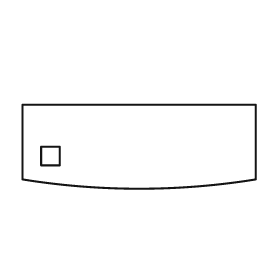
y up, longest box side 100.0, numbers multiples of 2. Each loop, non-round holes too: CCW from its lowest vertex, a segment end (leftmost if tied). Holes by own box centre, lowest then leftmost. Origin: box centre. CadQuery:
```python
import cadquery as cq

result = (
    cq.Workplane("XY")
    .moveTo(-50.0, -14.0)
    .threePointArc((0.0, -18.0), (50.0, -14.0))
    .lineTo(50.0, 18.0)
    .lineTo(-50.0, 18.0)
    .close()
    .moveTo(-42.0, -8.0)
    .lineTo(-34.0, -8.0)
    .lineTo(-34.0, 0.0)
    .lineTo(-42.0, 0.0)
    .close()
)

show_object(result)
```